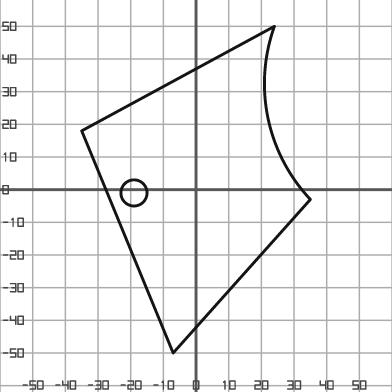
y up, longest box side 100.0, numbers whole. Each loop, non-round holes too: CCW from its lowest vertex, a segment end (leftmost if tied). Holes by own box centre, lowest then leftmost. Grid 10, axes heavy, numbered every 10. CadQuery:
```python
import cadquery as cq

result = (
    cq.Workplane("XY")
    .moveTo(-7.0, -50.0)
    .lineTo(35.0, -3.0)
    .threePointArc((22.0, 22.0), (24.0, 50.0))
    .lineTo(-35.0, 18.0)
    .close()
    .moveTo(-19.0, -1.0)
    .circle(4.0)
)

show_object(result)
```